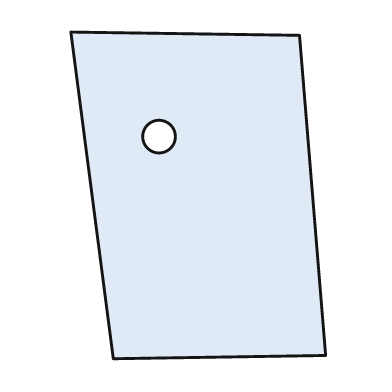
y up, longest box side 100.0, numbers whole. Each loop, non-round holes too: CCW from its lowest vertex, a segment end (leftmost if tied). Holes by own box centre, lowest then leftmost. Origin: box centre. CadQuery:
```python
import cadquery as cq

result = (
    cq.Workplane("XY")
    .moveTo(-26.0, -50.0)
    .lineTo(39.0, -49.0)
    .lineTo(31.0, 49.0)
    .lineTo(-39.0, 50.0)
    .close()
    .moveTo(-12.0, 18.0)
    .circle(5.0)
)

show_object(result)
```